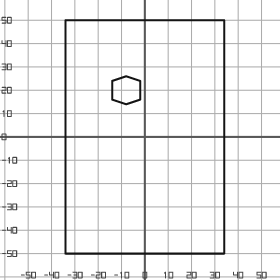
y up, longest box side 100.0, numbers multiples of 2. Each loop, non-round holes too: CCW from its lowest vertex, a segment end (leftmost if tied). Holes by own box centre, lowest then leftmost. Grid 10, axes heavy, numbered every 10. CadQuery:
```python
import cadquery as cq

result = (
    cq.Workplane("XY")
    .moveTo(-34.0, -50.0)
    .lineTo(34.0, -50.0)
    .lineTo(34.0, 50.0)
    .lineTo(-34.0, 50.0)
    .close()
    .moveTo(-8.0, 14.0)
    .lineTo(-2.0, 16.0)
    .lineTo(-2.0, 24.0)
    .lineTo(-8.0, 26.0)
    .lineTo(-14.0, 24.0)
    .lineTo(-14.0, 16.0)
    .close()
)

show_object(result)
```